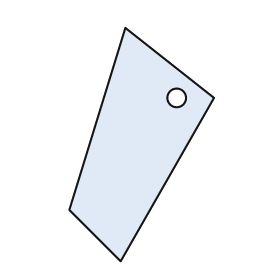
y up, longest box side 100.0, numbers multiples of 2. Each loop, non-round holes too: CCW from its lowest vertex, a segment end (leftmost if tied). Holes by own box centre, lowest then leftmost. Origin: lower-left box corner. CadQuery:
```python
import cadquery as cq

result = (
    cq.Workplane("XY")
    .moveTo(22.0, 0.0)
    .lineTo(62.0, 70.0)
    .lineTo(24.0, 100.0)
    .lineTo(0.0, 22.0)
    .close()
    .moveTo(46.0, 70.0)
    .circle(4.0)
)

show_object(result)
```